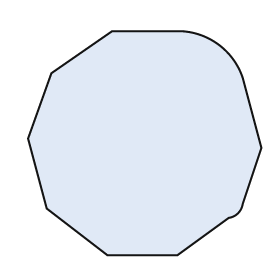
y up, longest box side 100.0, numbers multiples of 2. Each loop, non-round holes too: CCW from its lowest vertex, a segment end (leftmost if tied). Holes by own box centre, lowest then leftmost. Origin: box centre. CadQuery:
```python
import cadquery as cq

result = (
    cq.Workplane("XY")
    .moveTo(-16.0, -48.0)
    .lineTo(14.0, -48.0)
    .lineTo(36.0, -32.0)
    .threePointArc((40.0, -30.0), (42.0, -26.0))
    .lineTo(50.0, -2.0)
    .lineTo(42.0, 28.0)
    .threePointArc((32.0, 42.0), (16.0, 48.0))
    .lineTo(-14.0, 48.0)
    .lineTo(-40.0, 30.0)
    .lineTo(-50.0, 2.0)
    .lineTo(-42.0, -28.0)
    .close()
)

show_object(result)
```